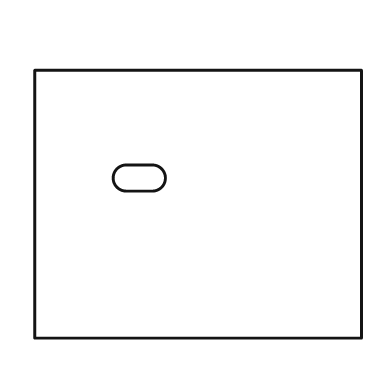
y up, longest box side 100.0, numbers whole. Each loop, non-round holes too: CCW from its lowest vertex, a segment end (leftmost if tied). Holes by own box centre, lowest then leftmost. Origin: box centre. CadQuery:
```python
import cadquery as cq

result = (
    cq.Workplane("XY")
    .moveTo(-50.0, -41.0)
    .lineTo(50.0, -41.0)
    .lineTo(50.0, 41.0)
    .lineTo(-50.0, 41.0)
    .close()
    .moveTo(-22.0, 4.0)
    .lineTo(-14.0, 4.0)
    .threePointArc((-10.0, 8.0), (-14.0, 12.0))
    .lineTo(-22.0, 12.0)
    .threePointArc((-26.0, 8.0), (-22.0, 4.0))
    .close()
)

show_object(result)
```